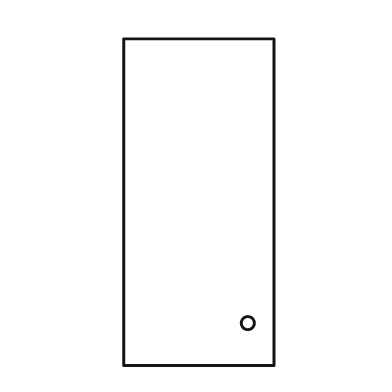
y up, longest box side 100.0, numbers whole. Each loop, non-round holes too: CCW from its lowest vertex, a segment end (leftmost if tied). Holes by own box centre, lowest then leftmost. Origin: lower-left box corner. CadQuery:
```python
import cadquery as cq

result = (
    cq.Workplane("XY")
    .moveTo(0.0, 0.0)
    .lineTo(46.0, 0.0)
    .lineTo(46.0, 100.0)
    .lineTo(0.0, 100.0)
    .close()
    .moveTo(38.0, 13.0)
    .circle(2.0)
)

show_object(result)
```